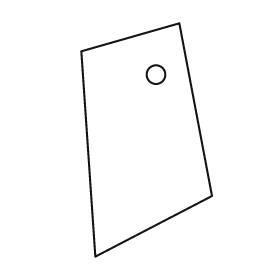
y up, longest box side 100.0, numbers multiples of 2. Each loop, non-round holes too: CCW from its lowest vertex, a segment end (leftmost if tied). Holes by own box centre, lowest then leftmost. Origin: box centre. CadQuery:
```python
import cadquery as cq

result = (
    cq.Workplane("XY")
    .moveTo(-22.0, -50.0)
    .lineTo(28.0, -24.0)
    .lineTo(14.0, 50.0)
    .lineTo(-28.0, 38.0)
    .close()
    .moveTo(4.0, 28.0)
    .circle(4.0)
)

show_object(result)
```